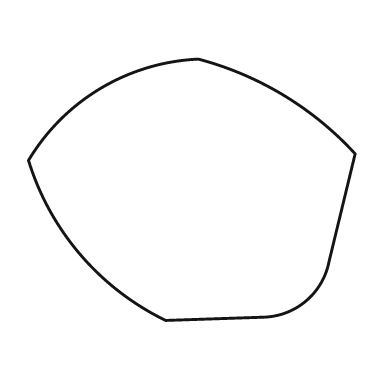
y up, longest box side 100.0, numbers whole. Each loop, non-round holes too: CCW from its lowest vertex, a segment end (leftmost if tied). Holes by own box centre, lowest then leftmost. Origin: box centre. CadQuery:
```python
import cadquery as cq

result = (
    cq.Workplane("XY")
    .moveTo(-8.0, -40.0)
    .lineTo(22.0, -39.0)
    .threePointArc((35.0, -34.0), (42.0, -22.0))
    .lineTo(50.0, 11.0)
    .threePointArc((28.0, 29.0), (2.0, 40.0))
    .threePointArc((-28.0, 31.0), (-50.0, 9.0))
    .threePointArc((-34.0, -20.0), (-8.0, -40.0))
    .close()
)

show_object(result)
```